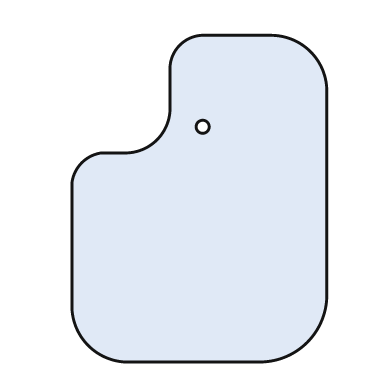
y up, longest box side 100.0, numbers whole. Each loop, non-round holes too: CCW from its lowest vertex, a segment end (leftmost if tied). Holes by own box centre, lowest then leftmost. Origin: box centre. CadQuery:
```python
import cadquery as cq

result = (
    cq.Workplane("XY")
    .moveTo(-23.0, -50.0)
    .lineTo(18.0, -50.0)
    .threePointArc((33.0, -44.0), (39.0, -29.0))
    .lineTo(39.0, 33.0)
    .threePointArc((34.0, 45.0), (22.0, 50.0))
    .lineTo(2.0, 50.0)
    .threePointArc((-6.0, 47.0), (-9.0, 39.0))
    .lineTo(-9.0, 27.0)
    .threePointArc((-13.0, 18.0), (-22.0, 14.0))
    .lineTo(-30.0, 14.0)
    .threePointArc((-36.0, 11.0), (-39.0, 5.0))
    .lineTo(-39.0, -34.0)
    .threePointArc((-34.0, -45.0), (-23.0, -50.0))
    .close()
    .moveTo(1.0, 22.0)
    .circle(2.0)
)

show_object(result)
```